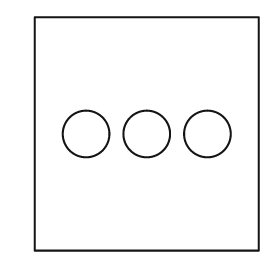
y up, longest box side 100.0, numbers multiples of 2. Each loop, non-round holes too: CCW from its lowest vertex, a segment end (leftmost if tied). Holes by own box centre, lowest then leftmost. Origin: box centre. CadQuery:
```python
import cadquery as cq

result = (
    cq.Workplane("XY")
    .moveTo(-48.0, -50.0)
    .lineTo(48.0, -50.0)
    .lineTo(48.0, 50.0)
    .lineTo(-48.0, 50.0)
    .close()
    .moveTo(-26.0, 0.0)
    .circle(10.0)
    .moveTo(0.0, 0.0)
    .circle(10.0)
    .moveTo(26.0, 0.0)
    .circle(10.0)
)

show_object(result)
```